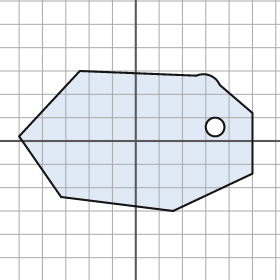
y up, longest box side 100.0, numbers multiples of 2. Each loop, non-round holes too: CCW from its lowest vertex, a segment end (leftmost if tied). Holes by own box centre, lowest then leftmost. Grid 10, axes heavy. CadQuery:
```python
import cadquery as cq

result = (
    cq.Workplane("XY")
    .moveTo(16.0, -30.0)
    .lineTo(50.0, -14.0)
    .lineTo(50.0, 12.0)
    .lineTo(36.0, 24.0)
    .threePointArc((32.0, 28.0), (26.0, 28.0))
    .lineTo(-24.0, 30.0)
    .lineTo(-50.0, 2.0)
    .lineTo(-32.0, -24.0)
    .close()
    .moveTo(34.0, 6.0)
    .circle(4.0)
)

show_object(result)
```